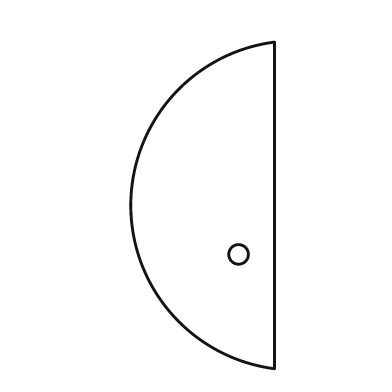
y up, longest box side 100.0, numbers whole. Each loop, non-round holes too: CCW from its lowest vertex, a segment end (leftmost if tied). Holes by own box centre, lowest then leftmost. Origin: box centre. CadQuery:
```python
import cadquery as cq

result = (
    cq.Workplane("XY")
    .moveTo(22.0, -50.0)
    .lineTo(22.0, 50.0)
    .threePointArc((-22.0, 0.0), (22.0, -50.0))
    .close()
    .moveTo(11.0, -15.0)
    .circle(3.0)
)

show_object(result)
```